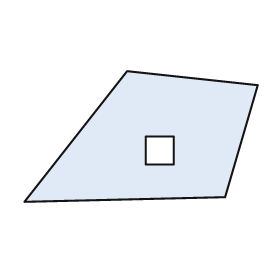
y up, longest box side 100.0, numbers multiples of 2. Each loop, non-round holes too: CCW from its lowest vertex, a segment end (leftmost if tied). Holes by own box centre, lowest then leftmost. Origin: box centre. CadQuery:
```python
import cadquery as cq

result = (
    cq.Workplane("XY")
    .moveTo(-50.0, -28.0)
    .lineTo(36.0, -26.0)
    .lineTo(50.0, 22.0)
    .lineTo(-6.0, 28.0)
    .close()
    .moveTo(2.0, -12.0)
    .lineTo(14.0, -12.0)
    .lineTo(14.0, 0.0)
    .lineTo(2.0, 0.0)
    .close()
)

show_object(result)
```